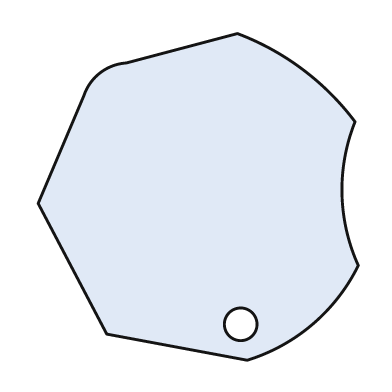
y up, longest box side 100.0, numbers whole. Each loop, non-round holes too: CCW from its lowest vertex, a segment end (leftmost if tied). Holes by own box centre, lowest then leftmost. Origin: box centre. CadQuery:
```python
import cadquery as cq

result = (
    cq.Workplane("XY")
    .moveTo(15.0, -50.0)
    .threePointArc((35.0, -39.0), (49.0, -21.0))
    .threePointArc((44.0, 1.0), (48.0, 23.0))
    .threePointArc((32.0, 39.0), (12.0, 50.0))
    .lineTo(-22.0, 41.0)
    .threePointArc((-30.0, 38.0), (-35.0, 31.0))
    .lineTo(-49.0, -2.0)
    .lineTo(-28.0, -42.0)
    .close()
    .moveTo(13.0, -39.0)
    .circle(5.0)
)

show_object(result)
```